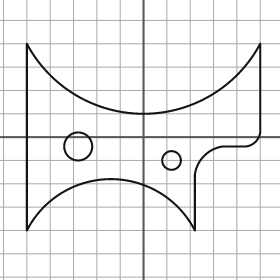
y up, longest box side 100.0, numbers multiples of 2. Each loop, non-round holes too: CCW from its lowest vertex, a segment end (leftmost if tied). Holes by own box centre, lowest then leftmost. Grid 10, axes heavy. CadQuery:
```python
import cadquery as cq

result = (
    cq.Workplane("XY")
    .moveTo(-50.0, -40.0)
    .threePointArc((-14.0, -18.0), (22.0, -40.0))
    .lineTo(22.0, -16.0)
    .threePointArc((26.0, -8.0), (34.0, -4.0))
    .lineTo(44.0, -4.0)
    .threePointArc((48.0, -2.0), (50.0, 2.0))
    .lineTo(50.0, 40.0)
    .threePointArc((0.0, 10.0), (-50.0, 40.0))
    .close()
    .moveTo(12.0, -10.0)
    .circle(4.0)
    .moveTo(-28.0, -4.0)
    .circle(6.0)
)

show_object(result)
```